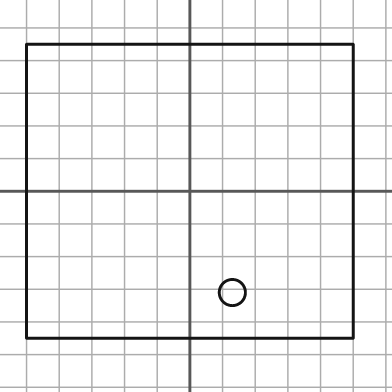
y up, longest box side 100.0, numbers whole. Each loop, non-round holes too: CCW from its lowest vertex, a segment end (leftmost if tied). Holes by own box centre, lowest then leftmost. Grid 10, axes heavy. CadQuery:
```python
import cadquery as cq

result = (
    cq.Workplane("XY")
    .moveTo(-50.0, -45.0)
    .lineTo(50.0, -45.0)
    .lineTo(50.0, 45.0)
    .lineTo(-50.0, 45.0)
    .close()
    .moveTo(13.0, -31.0)
    .circle(4.0)
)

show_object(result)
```